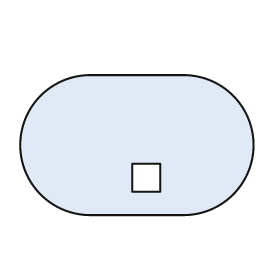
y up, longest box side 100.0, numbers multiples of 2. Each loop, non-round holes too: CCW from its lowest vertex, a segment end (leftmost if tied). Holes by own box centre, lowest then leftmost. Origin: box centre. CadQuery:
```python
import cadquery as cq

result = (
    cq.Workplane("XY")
    .moveTo(-20.0, -30.0)
    .lineTo(20.0, -30.0)
    .threePointArc((50.0, 0.0), (20.0, 30.0))
    .lineTo(-20.0, 30.0)
    .threePointArc((-50.0, 0.0), (-20.0, -30.0))
    .close()
    .moveTo(-2.0, -20.0)
    .lineTo(10.0, -20.0)
    .lineTo(10.0, -8.0)
    .lineTo(-2.0, -8.0)
    .close()
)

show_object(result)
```